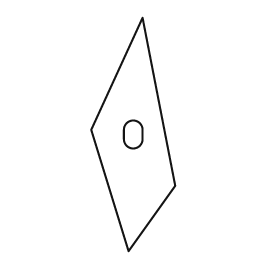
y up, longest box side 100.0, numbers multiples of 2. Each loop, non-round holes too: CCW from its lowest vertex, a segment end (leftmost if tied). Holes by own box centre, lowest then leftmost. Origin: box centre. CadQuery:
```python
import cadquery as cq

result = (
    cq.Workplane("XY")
    .moveTo(-2.0, -50.0)
    .lineTo(18.0, -22.0)
    .lineTo(4.0, 50.0)
    .lineTo(-18.0, 2.0)
    .close()
    .moveTo(-4.0, -2.0)
    .threePointArc((0.0, -6.0), (4.0, -2.0))
    .lineTo(4.0, 2.0)
    .threePointArc((0.0, 6.0), (-4.0, 2.0))
    .close()
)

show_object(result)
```